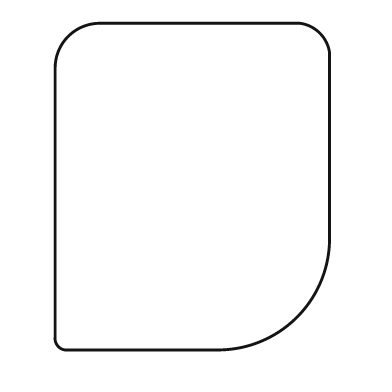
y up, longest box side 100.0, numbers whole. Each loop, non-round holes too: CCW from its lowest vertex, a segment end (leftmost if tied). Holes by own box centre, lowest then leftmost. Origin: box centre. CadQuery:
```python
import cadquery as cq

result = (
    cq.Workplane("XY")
    .moveTo(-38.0, -50.0)
    .lineTo(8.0, -50.0)
    .threePointArc((32.0, -40.0), (42.0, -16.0))
    .lineTo(42.0, 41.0)
    .threePointArc((39.0, 47.0), (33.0, 50.0))
    .lineTo(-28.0, 50.0)
    .threePointArc((-38.0, 46.0), (-42.0, 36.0))
    .lineTo(-42.0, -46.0)
    .threePointArc((-41.0, -49.0), (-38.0, -50.0))
    .close()
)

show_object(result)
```